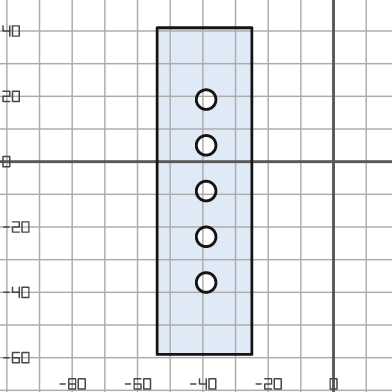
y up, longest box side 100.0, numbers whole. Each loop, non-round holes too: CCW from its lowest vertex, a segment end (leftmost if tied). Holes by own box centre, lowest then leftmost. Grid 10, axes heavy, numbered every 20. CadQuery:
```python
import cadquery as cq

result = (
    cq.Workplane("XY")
    .moveTo(-54.0, -59.0)
    .lineTo(-25.0, -59.0)
    .lineTo(-25.0, 41.0)
    .lineTo(-54.0, 41.0)
    .close()
    .moveTo(-39.0, -37.0)
    .circle(3.0)
    .moveTo(-39.0, -23.0)
    .circle(3.0)
    .moveTo(-39.0, -9.0)
    .circle(3.0)
    .moveTo(-39.0, 5.0)
    .circle(3.0)
    .moveTo(-39.0, 19.0)
    .circle(3.0)
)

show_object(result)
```